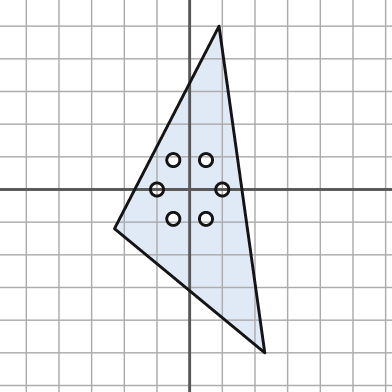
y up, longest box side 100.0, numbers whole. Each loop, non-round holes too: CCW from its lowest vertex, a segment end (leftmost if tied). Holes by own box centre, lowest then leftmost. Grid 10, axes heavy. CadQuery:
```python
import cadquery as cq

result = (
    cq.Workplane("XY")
    .moveTo(23.0, -50.0)
    .lineTo(9.0, 50.0)
    .lineTo(-23.0, -12.0)
    .close()
    .moveTo(-5.0, -9.0)
    .circle(2.0)
    .moveTo(5.0, -9.0)
    .circle(2.0)
    .moveTo(-10.0, 0.0)
    .circle(2.0)
    .moveTo(10.0, 0.0)
    .circle(2.0)
    .moveTo(-5.0, 9.0)
    .circle(2.0)
    .moveTo(5.0, 9.0)
    .circle(2.0)
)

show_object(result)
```